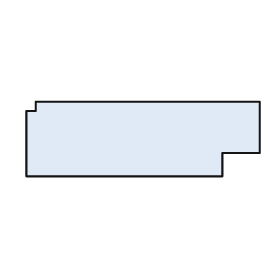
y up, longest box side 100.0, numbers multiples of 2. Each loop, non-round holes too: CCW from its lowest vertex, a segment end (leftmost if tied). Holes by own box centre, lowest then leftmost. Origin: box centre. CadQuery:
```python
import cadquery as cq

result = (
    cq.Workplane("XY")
    .moveTo(-50.0, -16.0)
    .lineTo(34.0, -16.0)
    .lineTo(34.0, -6.0)
    .lineTo(50.0, -6.0)
    .lineTo(50.0, 16.0)
    .lineTo(-46.0, 16.0)
    .lineTo(-46.0, 12.0)
    .lineTo(-50.0, 12.0)
    .close()
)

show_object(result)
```